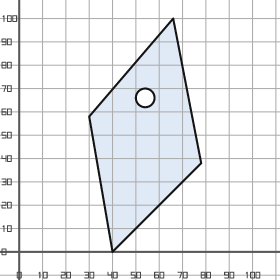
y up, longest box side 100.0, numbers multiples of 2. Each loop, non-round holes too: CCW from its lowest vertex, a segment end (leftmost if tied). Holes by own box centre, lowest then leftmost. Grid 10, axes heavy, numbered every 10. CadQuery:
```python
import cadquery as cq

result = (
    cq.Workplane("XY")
    .moveTo(40.0, 0.0)
    .lineTo(78.0, 38.0)
    .lineTo(66.0, 100.0)
    .lineTo(30.0, 58.0)
    .close()
    .moveTo(54.0, 66.0)
    .circle(4.0)
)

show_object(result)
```